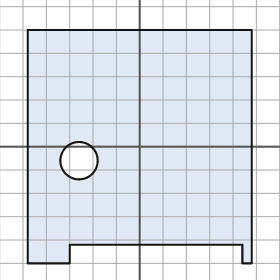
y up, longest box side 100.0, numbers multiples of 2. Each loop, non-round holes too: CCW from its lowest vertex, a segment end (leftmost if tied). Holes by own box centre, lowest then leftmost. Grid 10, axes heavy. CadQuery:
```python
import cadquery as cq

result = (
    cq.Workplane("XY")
    .moveTo(-48.0, -50.0)
    .lineTo(-30.0, -50.0)
    .lineTo(-30.0, -42.0)
    .lineTo(44.0, -42.0)
    .lineTo(44.0, -50.0)
    .lineTo(48.0, -50.0)
    .lineTo(48.0, 50.0)
    .lineTo(-48.0, 50.0)
    .close()
    .moveTo(-26.0, -6.0)
    .circle(8.0)
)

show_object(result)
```